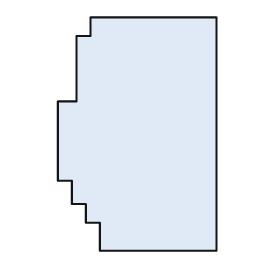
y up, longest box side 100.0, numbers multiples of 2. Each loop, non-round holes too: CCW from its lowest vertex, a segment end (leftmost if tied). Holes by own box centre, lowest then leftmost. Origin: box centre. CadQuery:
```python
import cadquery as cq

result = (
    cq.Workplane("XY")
    .moveTo(-16.0, -50.0)
    .lineTo(34.0, -50.0)
    .lineTo(34.0, 50.0)
    .lineTo(-20.0, 50.0)
    .lineTo(-20.0, 42.0)
    .lineTo(-26.0, 42.0)
    .lineTo(-26.0, 14.0)
    .lineTo(-34.0, 14.0)
    .lineTo(-34.0, -20.0)
    .lineTo(-28.0, -20.0)
    .lineTo(-28.0, -30.0)
    .lineTo(-22.0, -30.0)
    .lineTo(-22.0, -38.0)
    .lineTo(-16.0, -38.0)
    .close()
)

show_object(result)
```